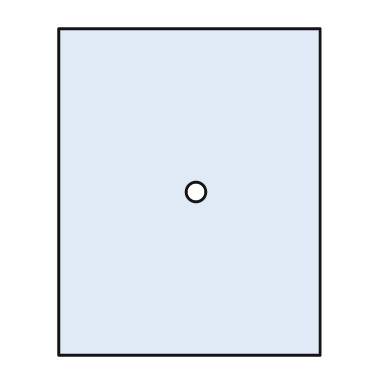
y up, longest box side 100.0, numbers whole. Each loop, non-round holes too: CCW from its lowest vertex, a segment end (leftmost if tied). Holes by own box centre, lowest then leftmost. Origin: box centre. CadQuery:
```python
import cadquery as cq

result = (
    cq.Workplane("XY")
    .moveTo(-40.0, -50.0)
    .lineTo(40.0, -50.0)
    .lineTo(40.0, 50.0)
    .lineTo(-40.0, 50.0)
    .close()
    .moveTo(2.0, 0.0)
    .circle(3.0)
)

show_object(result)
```